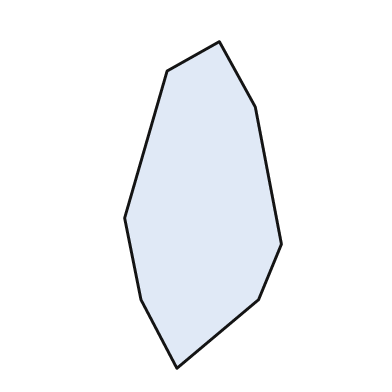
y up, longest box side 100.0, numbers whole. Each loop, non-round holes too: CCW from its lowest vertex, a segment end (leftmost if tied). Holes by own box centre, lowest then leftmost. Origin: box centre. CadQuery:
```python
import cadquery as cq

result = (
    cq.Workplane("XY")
    .moveTo(-8.0, -50.0)
    .lineTo(17.0, -29.0)
    .lineTo(24.0, -12.0)
    .lineTo(16.0, 30.0)
    .lineTo(5.0, 50.0)
    .lineTo(-11.0, 41.0)
    .lineTo(-24.0, -4.0)
    .lineTo(-19.0, -29.0)
    .close()
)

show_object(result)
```